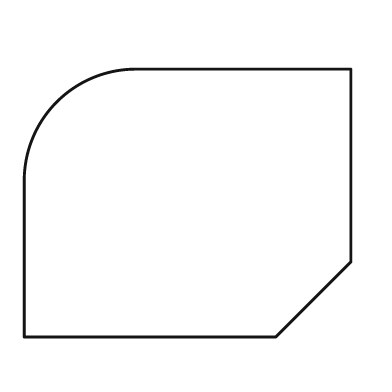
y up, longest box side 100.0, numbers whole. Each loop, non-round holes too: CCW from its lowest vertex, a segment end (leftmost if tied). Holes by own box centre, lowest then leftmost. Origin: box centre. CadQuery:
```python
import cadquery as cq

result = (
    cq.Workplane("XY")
    .moveTo(-50.0, -41.0)
    .lineTo(27.0, -41.0)
    .lineTo(50.0, -18.0)
    .lineTo(50.0, 41.0)
    .lineTo(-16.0, 41.0)
    .threePointArc((-40.0, 31.0), (-50.0, 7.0))
    .close()
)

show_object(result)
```